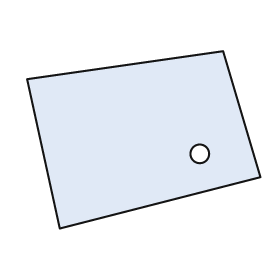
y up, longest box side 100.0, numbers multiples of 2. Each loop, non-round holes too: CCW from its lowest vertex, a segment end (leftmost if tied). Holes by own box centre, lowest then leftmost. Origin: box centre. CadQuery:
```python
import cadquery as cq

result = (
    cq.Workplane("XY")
    .moveTo(-36.0, -38.0)
    .lineTo(50.0, -16.0)
    .lineTo(34.0, 38.0)
    .lineTo(-50.0, 26.0)
    .close()
    .moveTo(24.0, -6.0)
    .circle(4.0)
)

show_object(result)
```